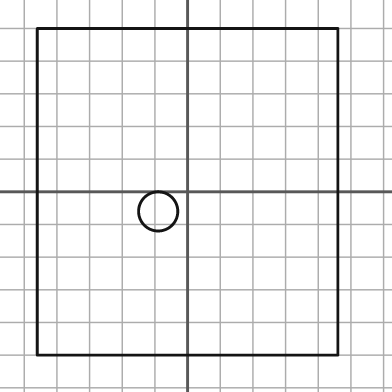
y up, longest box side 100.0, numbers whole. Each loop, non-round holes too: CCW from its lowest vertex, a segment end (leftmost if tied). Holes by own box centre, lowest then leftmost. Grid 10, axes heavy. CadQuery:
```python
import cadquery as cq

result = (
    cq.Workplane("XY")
    .moveTo(-46.0, -50.0)
    .lineTo(46.0, -50.0)
    .lineTo(46.0, 50.0)
    .lineTo(-46.0, 50.0)
    .close()
    .moveTo(-9.0, -6.0)
    .circle(6.0)
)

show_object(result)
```